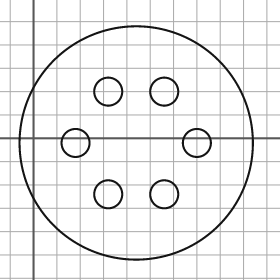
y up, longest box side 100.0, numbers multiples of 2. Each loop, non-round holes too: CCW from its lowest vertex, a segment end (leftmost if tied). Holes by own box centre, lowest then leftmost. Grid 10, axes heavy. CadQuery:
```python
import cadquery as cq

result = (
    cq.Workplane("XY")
    .moveTo(44.0, -2.0)
    .circle(50.0)
    .moveTo(32.0, -24.0)
    .circle(6.0)
    .moveTo(56.0, -24.0)
    .circle(6.0)
    .moveTo(18.0, -2.0)
    .circle(6.0)
    .moveTo(70.0, -2.0)
    .circle(6.0)
    .moveTo(32.0, 20.0)
    .circle(6.0)
    .moveTo(56.0, 20.0)
    .circle(6.0)
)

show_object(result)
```